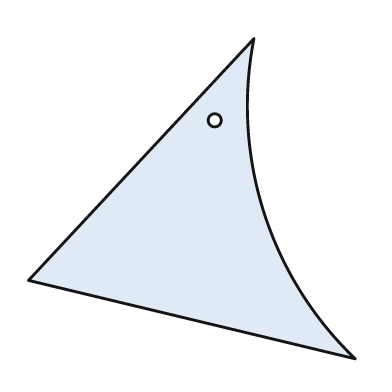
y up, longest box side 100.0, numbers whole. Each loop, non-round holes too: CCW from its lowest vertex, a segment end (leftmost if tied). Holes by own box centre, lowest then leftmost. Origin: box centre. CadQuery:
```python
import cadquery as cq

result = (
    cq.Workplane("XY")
    .moveTo(50.0, -49.0)
    .threePointArc((22.0, -4.0), (19.0, 49.0))
    .lineTo(-50.0, -25.0)
    .close()
    .moveTo(7.0, 24.0)
    .circle(2.0)
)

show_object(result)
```